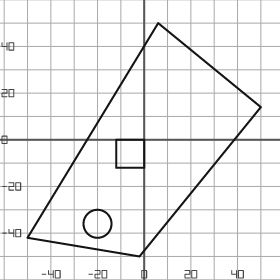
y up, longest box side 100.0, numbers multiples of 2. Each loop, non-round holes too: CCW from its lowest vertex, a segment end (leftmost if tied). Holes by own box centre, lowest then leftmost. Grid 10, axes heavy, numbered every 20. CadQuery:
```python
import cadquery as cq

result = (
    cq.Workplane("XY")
    .moveTo(-2.0, -50.0)
    .lineTo(50.0, 14.0)
    .lineTo(6.0, 50.0)
    .lineTo(-50.0, -42.0)
    .close()
    .moveTo(-20.0, -36.0)
    .circle(6.0)
    .moveTo(-12.0, -12.0)
    .lineTo(0.0, -12.0)
    .lineTo(0.0, 0.0)
    .lineTo(-12.0, 0.0)
    .close()
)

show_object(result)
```